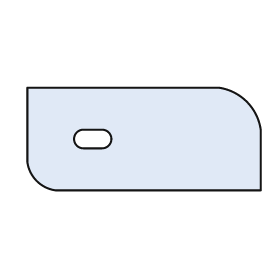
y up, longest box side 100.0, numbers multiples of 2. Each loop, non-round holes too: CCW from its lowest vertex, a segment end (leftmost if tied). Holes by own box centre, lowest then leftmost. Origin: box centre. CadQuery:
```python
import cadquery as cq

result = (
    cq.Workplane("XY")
    .moveTo(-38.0, -22.0)
    .lineTo(50.0, -22.0)
    .lineTo(50.0, 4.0)
    .threePointArc((44.0, 16.0), (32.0, 22.0))
    .lineTo(-50.0, 22.0)
    .lineTo(-50.0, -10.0)
    .threePointArc((-46.0, -18.0), (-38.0, -22.0))
    .close()
    .moveTo(-26.0, -4.0)
    .lineTo(-18.0, -4.0)
    .threePointArc((-14.0, 0.0), (-18.0, 4.0))
    .lineTo(-26.0, 4.0)
    .threePointArc((-30.0, 0.0), (-26.0, -4.0))
    .close()
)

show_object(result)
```